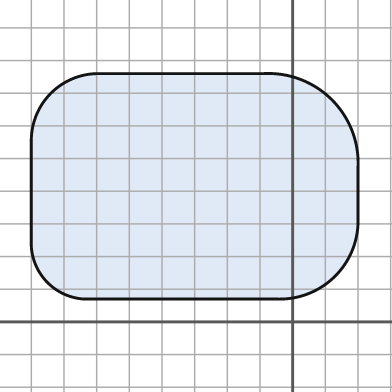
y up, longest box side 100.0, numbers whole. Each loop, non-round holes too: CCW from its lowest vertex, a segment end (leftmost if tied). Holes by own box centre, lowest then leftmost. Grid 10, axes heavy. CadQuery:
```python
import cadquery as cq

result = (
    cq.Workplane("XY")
    .moveTo(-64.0, 7.0)
    .lineTo(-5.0, 7.0)
    .threePointArc((13.0, 14.0), (20.0, 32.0))
    .lineTo(20.0, 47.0)
    .threePointArc((12.0, 68.0), (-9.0, 76.0))
    .lineTo(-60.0, 76.0)
    .threePointArc((-74.0, 70.0), (-80.0, 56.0))
    .lineTo(-80.0, 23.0)
    .threePointArc((-75.0, 12.0), (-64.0, 7.0))
    .close()
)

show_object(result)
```